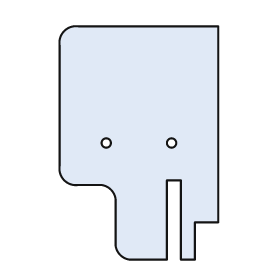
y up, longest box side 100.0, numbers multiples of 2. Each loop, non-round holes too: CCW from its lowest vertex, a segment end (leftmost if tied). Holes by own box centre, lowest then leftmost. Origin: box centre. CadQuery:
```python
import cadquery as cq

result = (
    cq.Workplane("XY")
    .moveTo(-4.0, -50.0)
    .lineTo(12.0, -50.0)
    .lineTo(12.0, -16.0)
    .lineTo(18.0, -16.0)
    .lineTo(18.0, -50.0)
    .lineTo(24.0, -50.0)
    .lineTo(24.0, -34.0)
    .lineTo(34.0, -34.0)
    .lineTo(34.0, 50.0)
    .lineTo(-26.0, 50.0)
    .threePointArc((-32.0, 48.0), (-34.0, 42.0))
    .lineTo(-34.0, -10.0)
    .threePointArc((-32.0, -16.0), (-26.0, -18.0))
    .lineTo(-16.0, -18.0)
    .threePointArc((-12.0, -20.0), (-10.0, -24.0))
    .lineTo(-10.0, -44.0)
    .threePointArc((-8.0, -48.0), (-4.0, -50.0))
    .close()
    .moveTo(-14.0, 0.0)
    .circle(2.0)
    .moveTo(14.0, 0.0)
    .circle(2.0)
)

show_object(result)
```